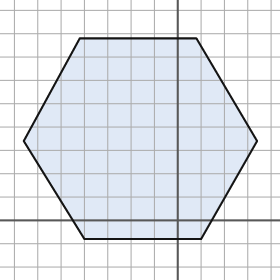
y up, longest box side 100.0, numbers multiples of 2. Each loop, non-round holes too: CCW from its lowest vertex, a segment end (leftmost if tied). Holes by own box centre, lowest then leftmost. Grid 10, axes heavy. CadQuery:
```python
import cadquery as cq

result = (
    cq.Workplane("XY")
    .moveTo(-40.0, -8.0)
    .lineTo(10.0, -8.0)
    .lineTo(34.0, 34.0)
    .lineTo(8.0, 78.0)
    .lineTo(-42.0, 78.0)
    .lineTo(-66.0, 34.0)
    .close()
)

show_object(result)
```